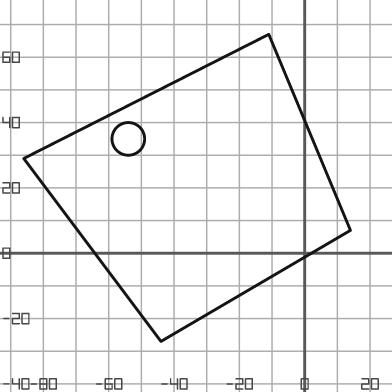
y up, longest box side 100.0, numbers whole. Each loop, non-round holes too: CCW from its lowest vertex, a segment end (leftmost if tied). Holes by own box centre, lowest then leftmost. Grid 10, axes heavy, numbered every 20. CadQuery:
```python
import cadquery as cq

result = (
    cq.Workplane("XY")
    .moveTo(-44.0, -27.0)
    .lineTo(14.0, 7.0)
    .lineTo(-11.0, 67.0)
    .lineTo(-86.0, 29.0)
    .close()
    .moveTo(-54.0, 35.0)
    .circle(5.0)
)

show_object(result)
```